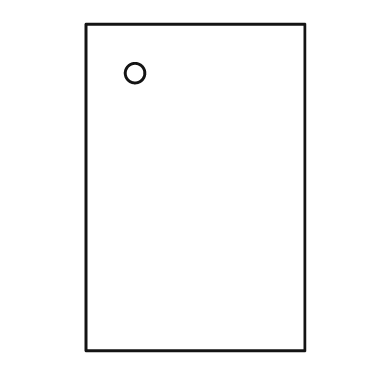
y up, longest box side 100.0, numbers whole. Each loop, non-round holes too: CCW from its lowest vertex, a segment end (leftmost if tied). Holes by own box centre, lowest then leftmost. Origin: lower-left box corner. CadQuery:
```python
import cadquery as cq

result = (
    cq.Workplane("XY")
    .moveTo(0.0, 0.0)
    .lineTo(67.0, 0.0)
    .lineTo(67.0, 100.0)
    .lineTo(0.0, 100.0)
    .close()
    .moveTo(15.0, 85.0)
    .circle(3.0)
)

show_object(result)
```